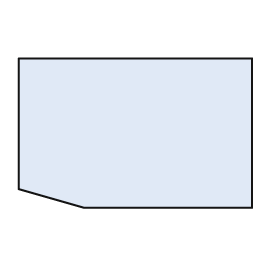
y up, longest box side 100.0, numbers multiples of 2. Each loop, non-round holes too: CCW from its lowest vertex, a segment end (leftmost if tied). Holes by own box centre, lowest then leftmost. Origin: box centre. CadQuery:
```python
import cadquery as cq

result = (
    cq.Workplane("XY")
    .moveTo(-22.0, -32.0)
    .lineTo(50.0, -32.0)
    .lineTo(50.0, 32.0)
    .lineTo(-50.0, 32.0)
    .lineTo(-50.0, -24.0)
    .close()
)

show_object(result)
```